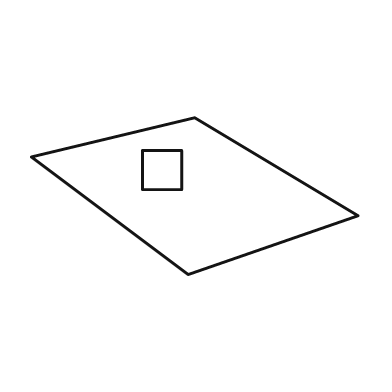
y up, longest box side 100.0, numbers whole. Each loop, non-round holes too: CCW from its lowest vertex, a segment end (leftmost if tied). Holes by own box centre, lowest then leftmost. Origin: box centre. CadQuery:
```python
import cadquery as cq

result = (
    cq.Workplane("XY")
    .moveTo(-2.0, -24.0)
    .lineTo(50.0, -6.0)
    .lineTo(0.0, 24.0)
    .lineTo(-50.0, 12.0)
    .close()
    .moveTo(-16.0, 2.0)
    .lineTo(-4.0, 2.0)
    .lineTo(-4.0, 14.0)
    .lineTo(-16.0, 14.0)
    .close()
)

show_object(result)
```